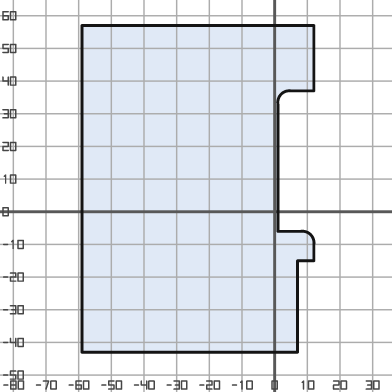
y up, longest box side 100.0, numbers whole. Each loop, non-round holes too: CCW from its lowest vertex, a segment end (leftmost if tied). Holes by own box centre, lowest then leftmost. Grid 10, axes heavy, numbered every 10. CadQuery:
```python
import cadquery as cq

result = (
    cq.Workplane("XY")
    .moveTo(-59.0, -43.0)
    .lineTo(7.0, -43.0)
    .lineTo(7.0, -15.0)
    .lineTo(12.0, -15.0)
    .lineTo(12.0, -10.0)
    .threePointArc((11.0, -7.0), (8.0, -6.0))
    .lineTo(1.0, -6.0)
    .lineTo(1.0, 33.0)
    .threePointArc((2.0, 36.0), (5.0, 37.0))
    .lineTo(12.0, 37.0)
    .lineTo(12.0, 57.0)
    .lineTo(-59.0, 57.0)
    .close()
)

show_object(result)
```